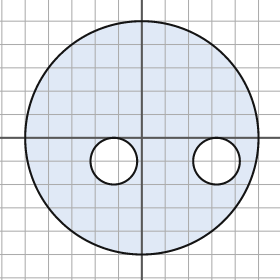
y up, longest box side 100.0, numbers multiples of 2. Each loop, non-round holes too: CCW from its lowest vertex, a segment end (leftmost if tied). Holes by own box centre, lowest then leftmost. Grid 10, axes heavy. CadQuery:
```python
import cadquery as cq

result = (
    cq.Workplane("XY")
    .moveTo(0.0, 0.0)
    .circle(50.0)
    .moveTo(-12.0, -10.0)
    .circle(10.0)
    .moveTo(32.0, -10.0)
    .circle(10.0)
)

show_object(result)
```